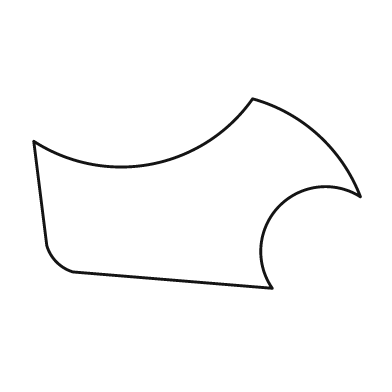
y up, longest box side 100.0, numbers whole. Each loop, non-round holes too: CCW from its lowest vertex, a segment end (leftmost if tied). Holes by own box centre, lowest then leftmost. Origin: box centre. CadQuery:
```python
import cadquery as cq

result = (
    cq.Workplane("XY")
    .moveTo(23.0, -29.0)
    .threePointArc((25.0, -4.0), (50.0, -1.0))
    .threePointArc((37.0, 18.0), (17.0, 29.0))
    .threePointArc((-14.0, 9.0), (-50.0, 16.0))
    .lineTo(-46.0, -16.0)
    .threePointArc((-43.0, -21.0), (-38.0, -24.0))
    .close()
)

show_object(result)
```